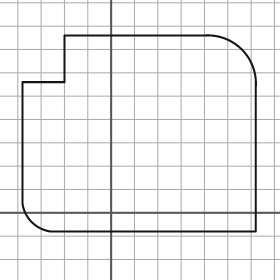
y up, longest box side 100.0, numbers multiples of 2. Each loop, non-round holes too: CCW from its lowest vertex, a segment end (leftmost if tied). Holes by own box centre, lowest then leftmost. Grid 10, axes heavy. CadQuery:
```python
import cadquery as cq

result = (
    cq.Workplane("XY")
    .moveTo(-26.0, -8.0)
    .lineTo(62.0, -8.0)
    .lineTo(62.0, 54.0)
    .threePointArc((56.0, 70.0), (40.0, 76.0))
    .lineTo(-20.0, 76.0)
    .lineTo(-20.0, 56.0)
    .lineTo(-38.0, 56.0)
    .lineTo(-38.0, 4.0)
    .threePointArc((-34.0, -4.0), (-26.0, -8.0))
    .close()
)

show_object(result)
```